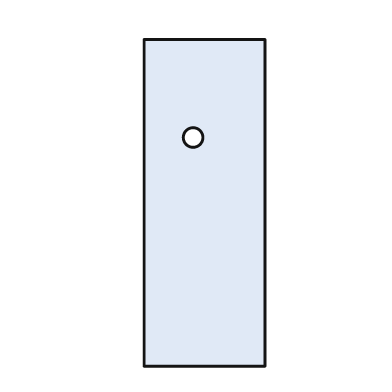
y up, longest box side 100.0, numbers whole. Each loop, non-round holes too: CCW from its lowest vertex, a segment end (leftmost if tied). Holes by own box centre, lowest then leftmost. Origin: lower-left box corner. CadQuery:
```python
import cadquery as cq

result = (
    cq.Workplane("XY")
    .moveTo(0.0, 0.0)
    .lineTo(37.0, 0.0)
    .lineTo(37.0, 100.0)
    .lineTo(0.0, 100.0)
    .close()
    .moveTo(15.0, 70.0)
    .circle(3.0)
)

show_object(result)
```